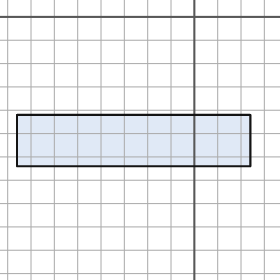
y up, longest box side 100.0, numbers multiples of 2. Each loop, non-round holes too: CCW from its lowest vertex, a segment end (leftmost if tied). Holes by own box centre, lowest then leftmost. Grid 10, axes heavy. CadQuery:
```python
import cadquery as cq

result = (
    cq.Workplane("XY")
    .moveTo(-76.0, -64.0)
    .lineTo(24.0, -64.0)
    .lineTo(24.0, -42.0)
    .lineTo(-76.0, -42.0)
    .close()
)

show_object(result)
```